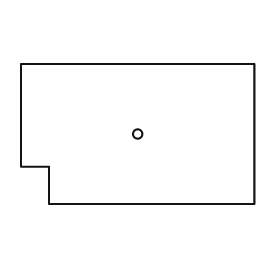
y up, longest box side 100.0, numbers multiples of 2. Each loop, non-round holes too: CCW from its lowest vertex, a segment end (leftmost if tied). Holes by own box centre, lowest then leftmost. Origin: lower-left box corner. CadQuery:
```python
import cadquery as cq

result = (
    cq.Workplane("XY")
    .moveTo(12.0, 0.0)
    .lineTo(100.0, 0.0)
    .lineTo(100.0, 60.0)
    .lineTo(0.0, 60.0)
    .lineTo(0.0, 16.0)
    .lineTo(12.0, 16.0)
    .close()
    .moveTo(50.0, 30.0)
    .circle(2.0)
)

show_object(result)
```